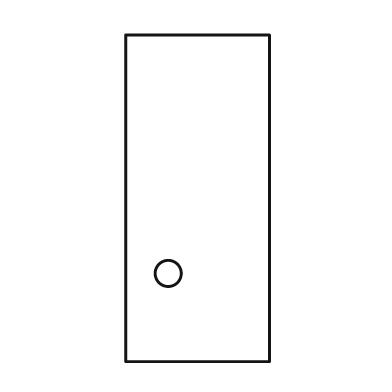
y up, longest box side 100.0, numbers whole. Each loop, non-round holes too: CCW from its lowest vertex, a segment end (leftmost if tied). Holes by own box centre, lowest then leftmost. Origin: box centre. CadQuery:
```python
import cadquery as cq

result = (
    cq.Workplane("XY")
    .moveTo(-22.0, -50.0)
    .lineTo(22.0, -50.0)
    .lineTo(22.0, 50.0)
    .lineTo(-22.0, 50.0)
    .close()
    .moveTo(-9.0, -23.0)
    .circle(4.0)
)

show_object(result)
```